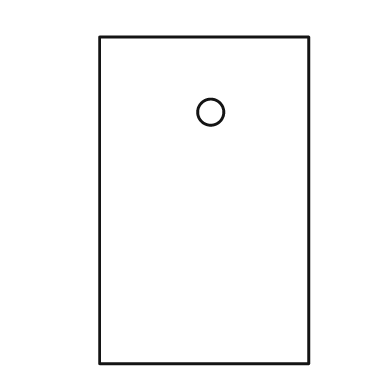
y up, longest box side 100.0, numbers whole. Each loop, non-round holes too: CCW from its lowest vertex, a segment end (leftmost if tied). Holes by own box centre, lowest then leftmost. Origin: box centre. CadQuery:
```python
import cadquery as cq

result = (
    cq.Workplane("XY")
    .moveTo(-32.0, -50.0)
    .lineTo(32.0, -50.0)
    .lineTo(32.0, 50.0)
    .lineTo(-32.0, 50.0)
    .close()
    .moveTo(2.0, 27.0)
    .circle(4.0)
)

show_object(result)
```